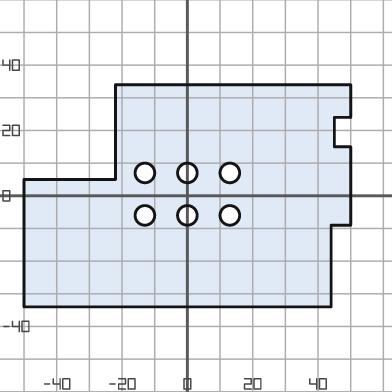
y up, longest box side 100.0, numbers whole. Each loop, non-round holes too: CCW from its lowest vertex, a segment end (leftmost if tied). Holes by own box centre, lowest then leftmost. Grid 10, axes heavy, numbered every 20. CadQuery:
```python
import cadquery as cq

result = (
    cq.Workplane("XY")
    .moveTo(-50.0, -34.0)
    .lineTo(44.0, -34.0)
    .lineTo(44.0, -9.0)
    .lineTo(50.0, -9.0)
    .lineTo(50.0, 15.0)
    .lineTo(45.0, 15.0)
    .lineTo(45.0, 24.0)
    .lineTo(50.0, 24.0)
    .lineTo(50.0, 34.0)
    .lineTo(-22.0, 34.0)
    .lineTo(-22.0, 5.0)
    .lineTo(-50.0, 5.0)
    .close()
    .moveTo(-13.0, -6.0)
    .circle(3.0)
    .moveTo(0.0, -6.0)
    .circle(3.0)
    .moveTo(13.0, -6.0)
    .circle(3.0)
    .moveTo(-13.0, 7.0)
    .circle(3.0)
    .moveTo(0.0, 7.0)
    .circle(3.0)
    .moveTo(13.0, 7.0)
    .circle(3.0)
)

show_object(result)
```